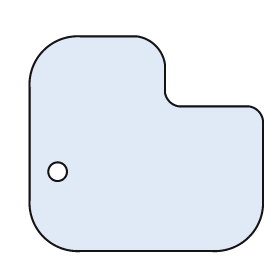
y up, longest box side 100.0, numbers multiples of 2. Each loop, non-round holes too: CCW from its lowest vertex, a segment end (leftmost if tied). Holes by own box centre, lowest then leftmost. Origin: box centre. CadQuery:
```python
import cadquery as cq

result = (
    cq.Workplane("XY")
    .moveTo(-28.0, -46.0)
    .lineTo(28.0, -46.0)
    .threePointArc((44.0, -40.0), (50.0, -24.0))
    .lineTo(50.0, 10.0)
    .threePointArc((48.0, 14.0), (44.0, 16.0))
    .lineTo(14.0, 16.0)
    .threePointArc((10.0, 18.0), (8.0, 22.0))
    .lineTo(8.0, 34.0)
    .threePointArc((4.0, 42.0), (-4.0, 46.0))
    .lineTo(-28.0, 46.0)
    .threePointArc((-44.0, 40.0), (-50.0, 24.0))
    .lineTo(-50.0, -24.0)
    .threePointArc((-44.0, -40.0), (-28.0, -46.0))
    .close()
    .moveTo(-38.0, -12.0)
    .circle(4.0)
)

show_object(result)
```